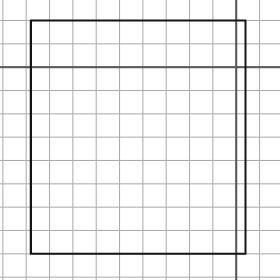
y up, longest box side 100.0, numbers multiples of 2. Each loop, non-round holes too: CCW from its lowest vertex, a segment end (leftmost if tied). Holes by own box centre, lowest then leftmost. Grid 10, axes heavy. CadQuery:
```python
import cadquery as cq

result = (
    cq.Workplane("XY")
    .moveTo(-88.0, -80.0)
    .lineTo(4.0, -80.0)
    .lineTo(4.0, 20.0)
    .lineTo(-88.0, 20.0)
    .close()
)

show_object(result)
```